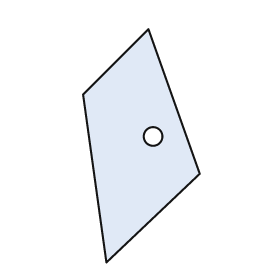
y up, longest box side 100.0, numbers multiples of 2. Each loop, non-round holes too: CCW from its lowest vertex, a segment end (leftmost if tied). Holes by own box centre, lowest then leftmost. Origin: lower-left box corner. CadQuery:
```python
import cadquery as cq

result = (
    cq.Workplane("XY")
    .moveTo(10.0, 0.0)
    .lineTo(50.0, 38.0)
    .lineTo(28.0, 100.0)
    .lineTo(0.0, 72.0)
    .close()
    .moveTo(30.0, 54.0)
    .circle(4.0)
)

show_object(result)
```